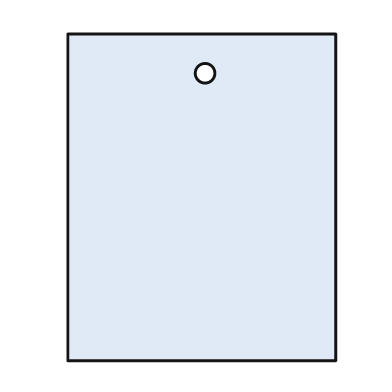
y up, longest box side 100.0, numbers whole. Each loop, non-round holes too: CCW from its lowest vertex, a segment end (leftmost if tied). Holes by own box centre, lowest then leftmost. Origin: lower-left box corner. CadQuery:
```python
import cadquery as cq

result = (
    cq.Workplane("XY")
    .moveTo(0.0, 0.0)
    .lineTo(82.0, 0.0)
    .lineTo(82.0, 100.0)
    .lineTo(0.0, 100.0)
    .close()
    .moveTo(42.0, 88.0)
    .circle(3.0)
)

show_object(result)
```